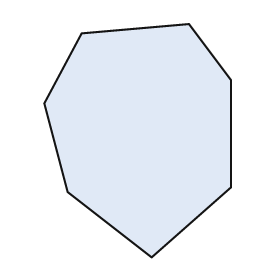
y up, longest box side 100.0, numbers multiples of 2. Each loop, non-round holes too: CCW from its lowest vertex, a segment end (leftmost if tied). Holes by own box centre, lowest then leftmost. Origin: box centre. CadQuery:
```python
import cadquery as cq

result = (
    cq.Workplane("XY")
    .moveTo(6.0, -50.0)
    .lineTo(40.0, -20.0)
    .lineTo(40.0, 26.0)
    .lineTo(22.0, 50.0)
    .lineTo(-24.0, 46.0)
    .lineTo(-40.0, 16.0)
    .lineTo(-30.0, -22.0)
    .close()
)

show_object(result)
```